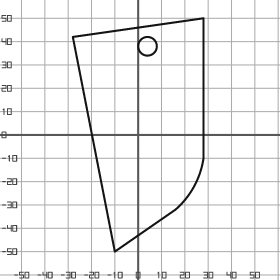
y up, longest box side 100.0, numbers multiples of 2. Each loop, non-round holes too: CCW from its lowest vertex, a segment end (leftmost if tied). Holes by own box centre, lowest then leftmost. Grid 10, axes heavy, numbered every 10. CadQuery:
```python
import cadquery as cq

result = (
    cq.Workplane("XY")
    .moveTo(-10.0, -50.0)
    .lineTo(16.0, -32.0)
    .threePointArc((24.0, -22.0), (28.0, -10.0))
    .lineTo(28.0, 50.0)
    .lineTo(-28.0, 42.0)
    .close()
    .moveTo(4.0, 38.0)
    .circle(4.0)
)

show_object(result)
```